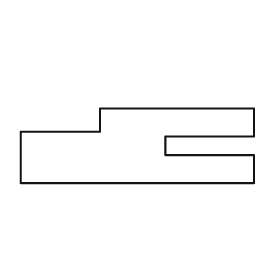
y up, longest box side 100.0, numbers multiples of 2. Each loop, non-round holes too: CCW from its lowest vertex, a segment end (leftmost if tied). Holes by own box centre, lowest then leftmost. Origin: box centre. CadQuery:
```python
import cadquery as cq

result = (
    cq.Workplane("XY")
    .moveTo(-50.0, -16.0)
    .lineTo(50.0, -16.0)
    .lineTo(50.0, -4.0)
    .lineTo(12.0, -4.0)
    .lineTo(12.0, 4.0)
    .lineTo(50.0, 4.0)
    .lineTo(50.0, 16.0)
    .lineTo(-16.0, 16.0)
    .lineTo(-16.0, 6.0)
    .lineTo(-50.0, 6.0)
    .close()
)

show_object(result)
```